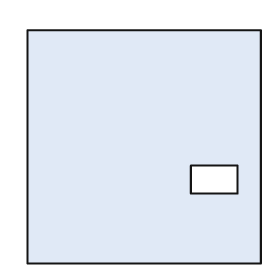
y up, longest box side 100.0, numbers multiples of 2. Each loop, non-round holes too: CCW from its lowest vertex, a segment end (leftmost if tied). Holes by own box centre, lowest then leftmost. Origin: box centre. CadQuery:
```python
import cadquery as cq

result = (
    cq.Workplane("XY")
    .moveTo(-50.0, -50.0)
    .lineTo(50.0, -50.0)
    .lineTo(50.0, 50.0)
    .lineTo(-50.0, 50.0)
    .close()
    .moveTo(20.0, -20.0)
    .lineTo(40.0, -20.0)
    .lineTo(40.0, -8.0)
    .lineTo(20.0, -8.0)
    .close()
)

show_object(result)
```